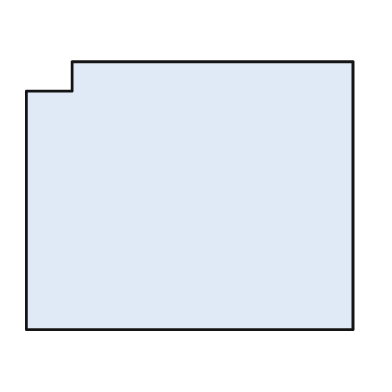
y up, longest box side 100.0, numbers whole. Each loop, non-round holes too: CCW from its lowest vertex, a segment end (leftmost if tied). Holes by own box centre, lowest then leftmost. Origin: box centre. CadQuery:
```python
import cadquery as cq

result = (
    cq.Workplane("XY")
    .moveTo(-50.0, -41.0)
    .lineTo(50.0, -41.0)
    .lineTo(50.0, 41.0)
    .lineTo(-36.0, 41.0)
    .lineTo(-36.0, 32.0)
    .lineTo(-50.0, 32.0)
    .close()
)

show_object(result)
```